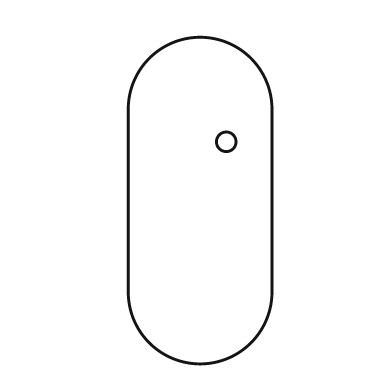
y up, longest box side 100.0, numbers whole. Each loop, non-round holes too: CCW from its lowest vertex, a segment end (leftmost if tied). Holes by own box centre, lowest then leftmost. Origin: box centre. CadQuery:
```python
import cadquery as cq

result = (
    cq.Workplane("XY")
    .moveTo(-22.0, -28.0)
    .threePointArc((0.0, -50.0), (22.0, -28.0))
    .lineTo(22.0, 28.0)
    .threePointArc((0.0, 50.0), (-22.0, 28.0))
    .close()
    .moveTo(8.0, 18.0)
    .circle(3.0)
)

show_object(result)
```